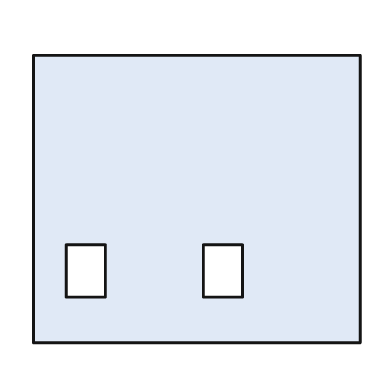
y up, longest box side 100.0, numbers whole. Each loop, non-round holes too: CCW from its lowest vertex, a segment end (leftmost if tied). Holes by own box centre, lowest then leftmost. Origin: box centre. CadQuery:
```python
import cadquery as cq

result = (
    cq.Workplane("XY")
    .moveTo(-50.0, -44.0)
    .lineTo(50.0, -44.0)
    .lineTo(50.0, 44.0)
    .lineTo(-50.0, 44.0)
    .close()
    .moveTo(-40.0, -30.0)
    .lineTo(-28.0, -30.0)
    .lineTo(-28.0, -14.0)
    .lineTo(-40.0, -14.0)
    .close()
    .moveTo(2.0, -30.0)
    .lineTo(14.0, -30.0)
    .lineTo(14.0, -14.0)
    .lineTo(2.0, -14.0)
    .close()
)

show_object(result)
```